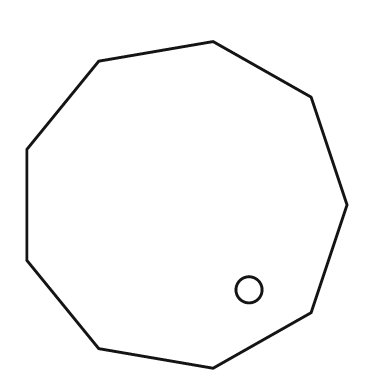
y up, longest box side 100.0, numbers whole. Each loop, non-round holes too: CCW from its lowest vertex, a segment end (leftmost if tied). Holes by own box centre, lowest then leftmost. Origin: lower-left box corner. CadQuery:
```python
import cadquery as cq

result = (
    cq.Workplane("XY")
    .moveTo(57.0, 0.0)
    .lineTo(87.0, 17.0)
    .lineTo(98.0, 50.0)
    .lineTo(87.0, 83.0)
    .lineTo(57.0, 100.0)
    .lineTo(22.0, 94.0)
    .lineTo(0.0, 67.0)
    .lineTo(0.0, 33.0)
    .lineTo(22.0, 6.0)
    .close()
    .moveTo(68.0, 24.0)
    .circle(4.0)
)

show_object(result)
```